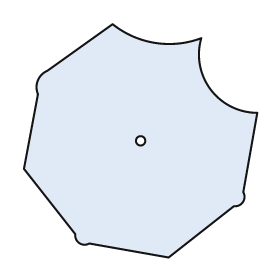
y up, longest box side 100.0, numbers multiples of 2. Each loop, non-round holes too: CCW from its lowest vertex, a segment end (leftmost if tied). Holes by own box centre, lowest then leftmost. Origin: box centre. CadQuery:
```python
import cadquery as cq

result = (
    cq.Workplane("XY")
    .moveTo(12.0, -50.0)
    .lineTo(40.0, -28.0)
    .threePointArc((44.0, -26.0), (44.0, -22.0))
    .lineTo(50.0, 12.0)
    .threePointArc((30.0, 22.0), (26.0, 44.0))
    .threePointArc((6.0, 42.0), (-12.0, 50.0))
    .lineTo(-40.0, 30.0)
    .threePointArc((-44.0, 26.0), (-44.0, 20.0))
    .lineTo(-50.0, -12.0)
    .lineTo(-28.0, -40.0)
    .threePointArc((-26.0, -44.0), (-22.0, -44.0))
    .close()
    .moveTo(0.0, 0.0)
    .circle(2.0)
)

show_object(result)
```